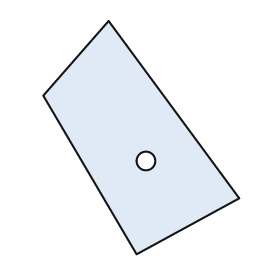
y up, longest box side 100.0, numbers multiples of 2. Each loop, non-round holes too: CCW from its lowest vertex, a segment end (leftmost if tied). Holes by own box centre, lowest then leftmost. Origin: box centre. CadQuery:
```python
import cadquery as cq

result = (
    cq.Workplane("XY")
    .moveTo(-2.0, -50.0)
    .lineTo(42.0, -26.0)
    .lineTo(-14.0, 50.0)
    .lineTo(-42.0, 18.0)
    .close()
    .moveTo(2.0, -10.0)
    .circle(4.0)
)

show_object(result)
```